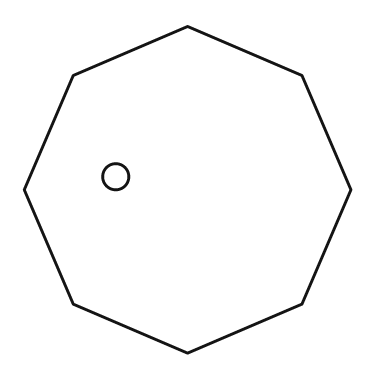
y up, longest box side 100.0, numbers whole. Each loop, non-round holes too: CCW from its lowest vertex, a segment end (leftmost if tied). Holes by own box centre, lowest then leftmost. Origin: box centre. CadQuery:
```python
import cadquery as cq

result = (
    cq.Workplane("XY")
    .moveTo(0.0, -50.0)
    .lineTo(35.0, -35.0)
    .lineTo(50.0, 0.0)
    .lineTo(35.0, 35.0)
    .lineTo(0.0, 50.0)
    .lineTo(-35.0, 35.0)
    .lineTo(-50.0, 0.0)
    .lineTo(-35.0, -35.0)
    .close()
    .moveTo(-22.0, 4.0)
    .circle(4.0)
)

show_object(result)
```